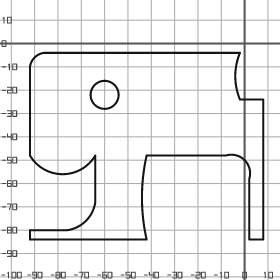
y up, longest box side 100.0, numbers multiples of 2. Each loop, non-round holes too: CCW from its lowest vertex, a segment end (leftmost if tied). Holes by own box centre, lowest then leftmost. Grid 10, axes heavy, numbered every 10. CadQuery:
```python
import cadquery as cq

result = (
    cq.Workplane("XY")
    .moveTo(-92.0, -84.0)
    .lineTo(-42.0, -84.0)
    .threePointArc((-44.0, -66.0), (-42.0, -48.0))
    .lineTo(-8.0, -48.0)
    .threePointArc((0.0, -50.0), (2.0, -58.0))
    .lineTo(2.0, -84.0)
    .lineTo(8.0, -84.0)
    .lineTo(8.0, -24.0)
    .lineTo(-2.0, -24.0)
    .threePointArc((-4.0, -14.0), (-2.0, -4.0))
    .lineTo(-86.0, -4.0)
    .threePointArc((-90.0, -6.0), (-92.0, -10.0))
    .lineTo(-92.0, -48.0)
    .threePointArc((-78.0, -56.0), (-64.0, -48.0))
    .lineTo(-64.0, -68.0)
    .threePointArc((-68.0, -76.0), (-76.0, -80.0))
    .lineTo(-92.0, -80.0)
    .close()
    .moveTo(-60.0, -22.0)
    .circle(6.0)
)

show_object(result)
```